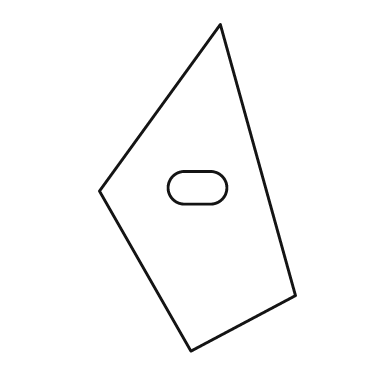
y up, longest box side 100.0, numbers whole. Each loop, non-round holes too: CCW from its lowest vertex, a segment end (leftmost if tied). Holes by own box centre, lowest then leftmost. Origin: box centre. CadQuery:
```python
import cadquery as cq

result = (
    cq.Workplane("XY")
    .moveTo(-2.0, -50.0)
    .lineTo(30.0, -33.0)
    .lineTo(7.0, 50.0)
    .lineTo(-30.0, -1.0)
    .close()
    .moveTo(-4.0, -5.0)
    .lineTo(4.0, -5.0)
    .threePointArc((9.0, 0.0), (4.0, 5.0))
    .lineTo(-4.0, 5.0)
    .threePointArc((-9.0, 0.0), (-4.0, -5.0))
    .close()
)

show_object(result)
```